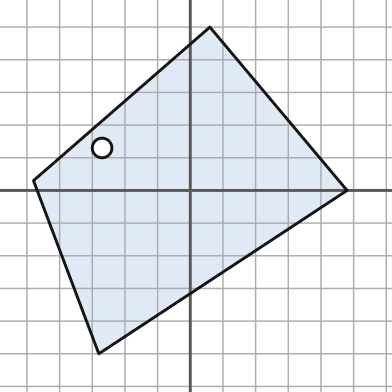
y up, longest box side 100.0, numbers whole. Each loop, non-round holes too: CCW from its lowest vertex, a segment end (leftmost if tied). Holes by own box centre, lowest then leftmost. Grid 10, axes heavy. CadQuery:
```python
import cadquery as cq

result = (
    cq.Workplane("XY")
    .moveTo(-28.0, -50.0)
    .lineTo(48.0, 0.0)
    .lineTo(6.0, 50.0)
    .lineTo(-48.0, 3.0)
    .close()
    .moveTo(-27.0, 13.0)
    .circle(3.0)
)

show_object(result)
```